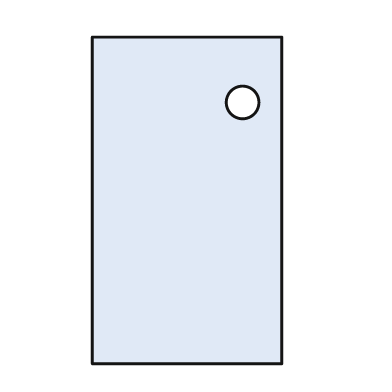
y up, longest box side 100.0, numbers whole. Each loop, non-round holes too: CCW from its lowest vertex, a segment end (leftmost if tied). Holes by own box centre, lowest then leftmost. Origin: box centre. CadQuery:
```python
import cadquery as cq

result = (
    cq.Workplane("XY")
    .moveTo(-29.0, -50.0)
    .lineTo(29.0, -50.0)
    .lineTo(29.0, 50.0)
    .lineTo(-29.0, 50.0)
    .close()
    .moveTo(17.0, 30.0)
    .circle(5.0)
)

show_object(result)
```